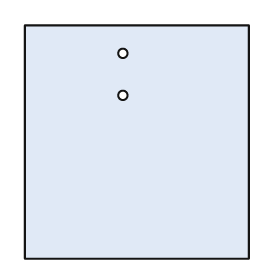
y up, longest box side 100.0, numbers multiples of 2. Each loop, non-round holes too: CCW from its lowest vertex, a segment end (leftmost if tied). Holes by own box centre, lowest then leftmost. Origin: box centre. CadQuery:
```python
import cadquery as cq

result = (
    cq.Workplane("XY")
    .moveTo(-48.0, -50.0)
    .lineTo(48.0, -50.0)
    .lineTo(48.0, 50.0)
    .lineTo(-48.0, 50.0)
    .close()
    .moveTo(-6.0, 20.0)
    .circle(2.0)
    .moveTo(-6.0, 38.0)
    .circle(2.0)
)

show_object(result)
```